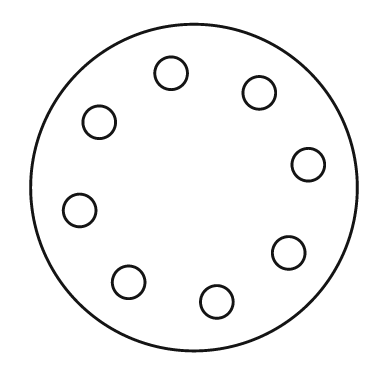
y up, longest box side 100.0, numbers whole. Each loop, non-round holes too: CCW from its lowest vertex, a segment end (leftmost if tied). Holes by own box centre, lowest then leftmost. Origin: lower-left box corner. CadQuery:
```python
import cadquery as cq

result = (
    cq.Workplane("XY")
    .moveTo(50.0, 50.0)
    .circle(50.0)
    .moveTo(57.0, 15.0)
    .circle(5.0)
    .moveTo(30.0, 21.0)
    .circle(5.0)
    .moveTo(79.0, 30.0)
    .circle(5.0)
    .moveTo(15.0, 43.0)
    .circle(5.0)
    .moveTo(85.0, 57.0)
    .circle(5.0)
    .moveTo(21.0, 70.0)
    .circle(5.0)
    .moveTo(70.0, 79.0)
    .circle(5.0)
    .moveTo(43.0, 85.0)
    .circle(5.0)
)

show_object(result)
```